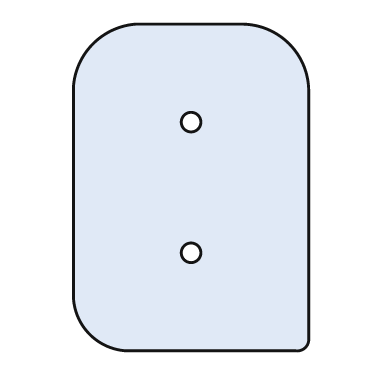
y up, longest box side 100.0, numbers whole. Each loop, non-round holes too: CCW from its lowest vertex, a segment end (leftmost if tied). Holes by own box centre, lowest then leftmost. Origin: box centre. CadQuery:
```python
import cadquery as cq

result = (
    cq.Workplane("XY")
    .moveTo(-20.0, -50.0)
    .lineTo(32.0, -50.0)
    .threePointArc((35.0, -49.0), (36.0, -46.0))
    .lineTo(36.0, 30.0)
    .threePointArc((30.0, 44.0), (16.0, 50.0))
    .lineTo(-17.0, 50.0)
    .threePointArc((-30.0, 44.0), (-36.0, 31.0))
    .lineTo(-36.0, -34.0)
    .threePointArc((-31.0, -45.0), (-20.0, -50.0))
    .close()
    .moveTo(0.0, -20.0)
    .circle(3.0)
    .moveTo(0.0, 20.0)
    .circle(3.0)
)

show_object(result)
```